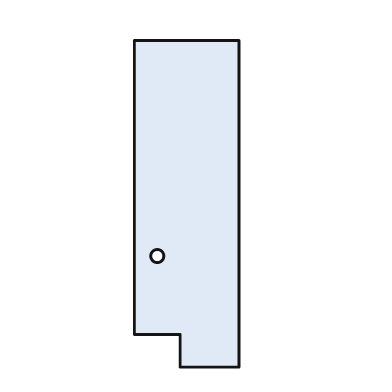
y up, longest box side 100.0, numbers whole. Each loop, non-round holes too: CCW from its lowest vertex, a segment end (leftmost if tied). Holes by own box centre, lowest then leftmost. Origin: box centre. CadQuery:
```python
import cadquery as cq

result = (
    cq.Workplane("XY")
    .moveTo(-2.0, -50.0)
    .lineTo(16.0, -50.0)
    .lineTo(16.0, 50.0)
    .lineTo(-16.0, 50.0)
    .lineTo(-16.0, -40.0)
    .lineTo(-2.0, -40.0)
    .close()
    .moveTo(-9.0, -16.0)
    .circle(2.0)
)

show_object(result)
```